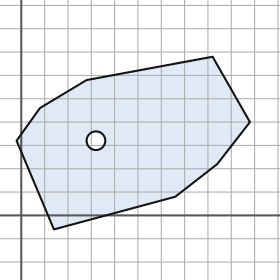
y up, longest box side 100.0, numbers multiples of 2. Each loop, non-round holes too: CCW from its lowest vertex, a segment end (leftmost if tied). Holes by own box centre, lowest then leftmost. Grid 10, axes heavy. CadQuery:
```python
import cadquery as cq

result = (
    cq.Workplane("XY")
    .moveTo(14.0, -6.0)
    .lineTo(66.0, 8.0)
    .lineTo(84.0, 22.0)
    .lineTo(98.0, 40.0)
    .lineTo(82.0, 68.0)
    .lineTo(28.0, 58.0)
    .lineTo(8.0, 46.0)
    .lineTo(-2.0, 32.0)
    .close()
    .moveTo(32.0, 32.0)
    .circle(4.0)
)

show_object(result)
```